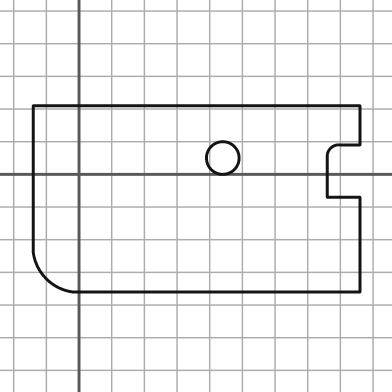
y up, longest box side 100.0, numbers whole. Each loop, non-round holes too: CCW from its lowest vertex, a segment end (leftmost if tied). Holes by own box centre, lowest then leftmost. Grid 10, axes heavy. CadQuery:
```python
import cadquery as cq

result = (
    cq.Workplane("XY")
    .moveTo(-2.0, -36.0)
    .lineTo(86.0, -36.0)
    .lineTo(86.0, -7.0)
    .lineTo(76.0, -7.0)
    .lineTo(76.0, 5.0)
    .threePointArc((77.0, 8.0), (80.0, 9.0))
    .lineTo(86.0, 9.0)
    .lineTo(86.0, 21.0)
    .lineTo(-14.0, 21.0)
    .lineTo(-14.0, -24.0)
    .threePointArc((-10.0, -32.0), (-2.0, -36.0))
    .close()
    .moveTo(44.0, 5.0)
    .circle(5.0)
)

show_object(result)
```